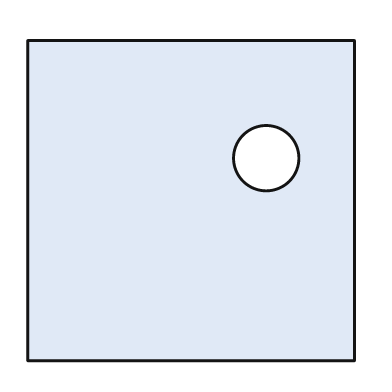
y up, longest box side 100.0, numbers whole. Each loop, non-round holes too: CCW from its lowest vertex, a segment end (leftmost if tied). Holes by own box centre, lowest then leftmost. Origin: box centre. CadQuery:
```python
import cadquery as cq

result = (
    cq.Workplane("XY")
    .moveTo(-50.0, -49.0)
    .lineTo(50.0, -49.0)
    .lineTo(50.0, 49.0)
    .lineTo(-50.0, 49.0)
    .close()
    .moveTo(23.0, 13.0)
    .circle(10.0)
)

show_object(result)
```